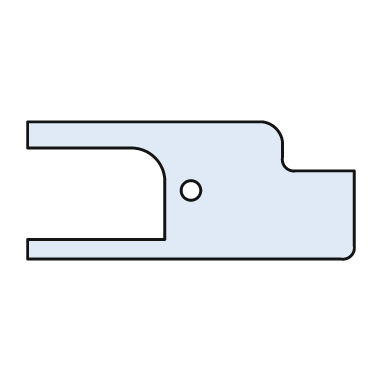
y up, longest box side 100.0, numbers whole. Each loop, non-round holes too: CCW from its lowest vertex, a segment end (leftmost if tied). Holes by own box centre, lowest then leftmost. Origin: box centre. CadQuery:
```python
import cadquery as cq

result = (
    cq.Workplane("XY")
    .moveTo(-50.0, -21.0)
    .lineTo(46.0, -21.0)
    .threePointArc((49.0, -20.0), (50.0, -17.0))
    .lineTo(50.0, 6.0)
    .lineTo(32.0, 6.0)
    .threePointArc((29.0, 7.0), (28.0, 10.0))
    .lineTo(28.0, 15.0)
    .threePointArc((26.0, 19.0), (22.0, 21.0))
    .lineTo(-50.0, 21.0)
    .lineTo(-50.0, 13.0)
    .lineTo(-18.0, 13.0)
    .threePointArc((-11.0, 10.0), (-8.0, 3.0))
    .lineTo(-8.0, -15.0)
    .lineTo(-50.0, -15.0)
    .close()
    .moveTo(0.0, 0.0)
    .circle(3.0)
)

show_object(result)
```